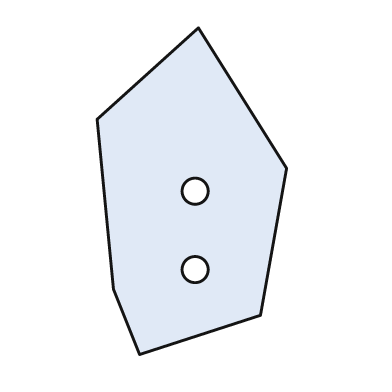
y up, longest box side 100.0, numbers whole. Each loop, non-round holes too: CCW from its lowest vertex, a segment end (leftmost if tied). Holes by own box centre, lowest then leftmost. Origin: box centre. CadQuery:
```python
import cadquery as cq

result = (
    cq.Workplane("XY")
    .moveTo(-16.0, -50.0)
    .lineTo(21.0, -38.0)
    .lineTo(29.0, 7.0)
    .lineTo(2.0, 50.0)
    .lineTo(-29.0, 22.0)
    .lineTo(-24.0, -30.0)
    .close()
    .moveTo(1.0, -24.0)
    .circle(4.0)
    .moveTo(1.0, 0.0)
    .circle(4.0)
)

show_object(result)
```